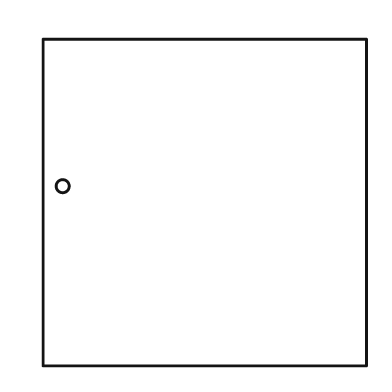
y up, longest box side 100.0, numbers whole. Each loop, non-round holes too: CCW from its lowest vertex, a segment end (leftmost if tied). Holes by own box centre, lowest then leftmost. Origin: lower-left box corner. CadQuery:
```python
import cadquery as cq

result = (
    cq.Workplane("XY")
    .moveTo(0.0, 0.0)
    .lineTo(99.0, 0.0)
    .lineTo(99.0, 100.0)
    .lineTo(0.0, 100.0)
    .close()
    .moveTo(6.0, 55.0)
    .circle(2.0)
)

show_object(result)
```